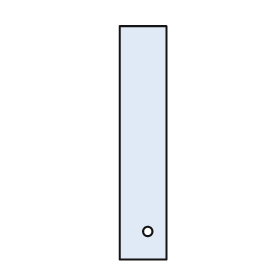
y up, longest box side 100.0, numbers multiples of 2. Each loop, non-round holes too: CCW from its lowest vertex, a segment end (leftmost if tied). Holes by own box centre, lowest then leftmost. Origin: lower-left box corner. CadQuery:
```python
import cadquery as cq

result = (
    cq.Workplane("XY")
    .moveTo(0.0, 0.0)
    .lineTo(20.0, 0.0)
    .lineTo(20.0, 100.0)
    .lineTo(0.0, 100.0)
    .close()
    .moveTo(12.0, 12.0)
    .circle(2.0)
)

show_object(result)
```